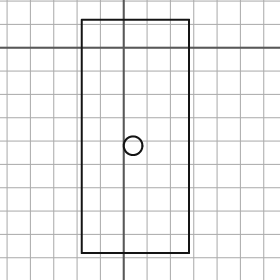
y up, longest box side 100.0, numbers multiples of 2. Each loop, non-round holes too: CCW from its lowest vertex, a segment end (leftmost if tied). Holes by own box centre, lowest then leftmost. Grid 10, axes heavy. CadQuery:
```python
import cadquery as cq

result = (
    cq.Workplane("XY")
    .moveTo(-18.0, -88.0)
    .lineTo(28.0, -88.0)
    .lineTo(28.0, 12.0)
    .lineTo(-18.0, 12.0)
    .close()
    .moveTo(4.0, -42.0)
    .circle(4.0)
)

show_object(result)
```